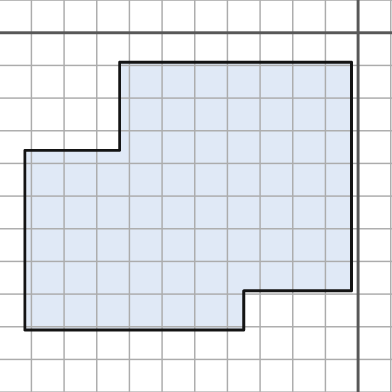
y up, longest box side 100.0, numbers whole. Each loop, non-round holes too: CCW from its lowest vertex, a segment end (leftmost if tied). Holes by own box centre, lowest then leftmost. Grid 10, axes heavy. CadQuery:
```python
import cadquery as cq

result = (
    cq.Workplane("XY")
    .moveTo(-102.0, -91.0)
    .lineTo(-35.0, -91.0)
    .lineTo(-35.0, -79.0)
    .lineTo(-2.0, -79.0)
    .lineTo(-2.0, -9.0)
    .lineTo(-73.0, -9.0)
    .lineTo(-73.0, -36.0)
    .lineTo(-102.0, -36.0)
    .close()
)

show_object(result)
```